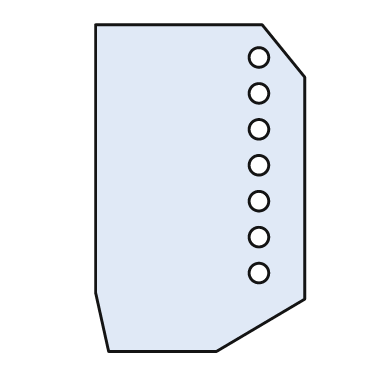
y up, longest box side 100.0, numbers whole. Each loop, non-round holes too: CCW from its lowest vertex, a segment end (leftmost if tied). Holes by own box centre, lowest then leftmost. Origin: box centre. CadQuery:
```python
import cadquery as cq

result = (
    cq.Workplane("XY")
    .moveTo(-28.0, -50.0)
    .lineTo(5.0, -50.0)
    .lineTo(32.0, -34.0)
    .lineTo(32.0, 34.0)
    .lineTo(19.0, 50.0)
    .lineTo(-32.0, 50.0)
    .lineTo(-32.0, -32.0)
    .close()
    .moveTo(18.0, -26.0)
    .circle(3.0)
    .moveTo(18.0, -15.0)
    .circle(3.0)
    .moveTo(18.0, -4.0)
    .circle(3.0)
    .moveTo(18.0, 7.0)
    .circle(3.0)
    .moveTo(18.0, 18.0)
    .circle(3.0)
    .moveTo(18.0, 29.0)
    .circle(3.0)
    .moveTo(18.0, 40.0)
    .circle(3.0)
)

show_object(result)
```